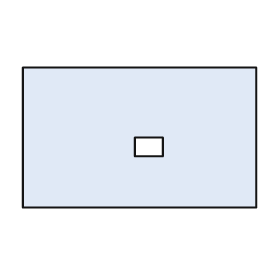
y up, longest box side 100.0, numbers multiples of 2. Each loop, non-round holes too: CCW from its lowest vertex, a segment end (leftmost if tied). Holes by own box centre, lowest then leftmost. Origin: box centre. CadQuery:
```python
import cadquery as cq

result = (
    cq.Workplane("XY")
    .moveTo(-50.0, -30.0)
    .lineTo(50.0, -30.0)
    .lineTo(50.0, 30.0)
    .lineTo(-50.0, 30.0)
    .close()
    .moveTo(-2.0, -8.0)
    .lineTo(10.0, -8.0)
    .lineTo(10.0, 0.0)
    .lineTo(-2.0, 0.0)
    .close()
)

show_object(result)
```